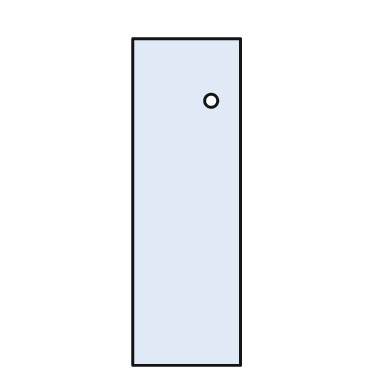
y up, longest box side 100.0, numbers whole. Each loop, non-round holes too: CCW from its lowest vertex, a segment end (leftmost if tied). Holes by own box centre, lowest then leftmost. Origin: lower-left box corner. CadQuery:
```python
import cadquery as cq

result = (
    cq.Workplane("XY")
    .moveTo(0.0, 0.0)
    .lineTo(33.0, 0.0)
    .lineTo(33.0, 100.0)
    .lineTo(0.0, 100.0)
    .close()
    .moveTo(24.0, 81.0)
    .circle(2.0)
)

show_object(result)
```